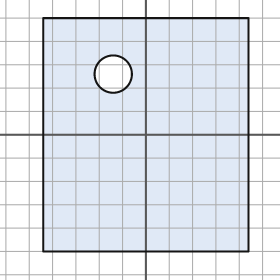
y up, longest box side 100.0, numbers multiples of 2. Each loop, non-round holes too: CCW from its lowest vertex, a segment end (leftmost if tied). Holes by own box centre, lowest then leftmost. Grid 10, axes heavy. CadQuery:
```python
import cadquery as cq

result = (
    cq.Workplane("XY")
    .moveTo(-44.0, -50.0)
    .lineTo(44.0, -50.0)
    .lineTo(44.0, 50.0)
    .lineTo(-44.0, 50.0)
    .close()
    .moveTo(-14.0, 26.0)
    .circle(8.0)
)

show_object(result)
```